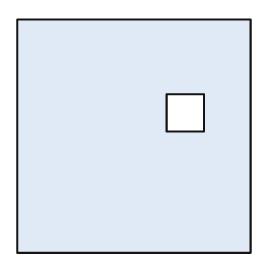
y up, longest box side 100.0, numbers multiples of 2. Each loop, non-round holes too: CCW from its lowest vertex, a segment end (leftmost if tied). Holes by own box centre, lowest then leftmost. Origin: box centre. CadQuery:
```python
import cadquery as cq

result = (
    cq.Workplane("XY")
    .moveTo(-50.0, -50.0)
    .lineTo(50.0, -50.0)
    .lineTo(50.0, 50.0)
    .lineTo(-50.0, 50.0)
    .close()
    .moveTo(14.0, 2.0)
    .lineTo(30.0, 2.0)
    .lineTo(30.0, 18.0)
    .lineTo(14.0, 18.0)
    .close()
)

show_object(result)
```